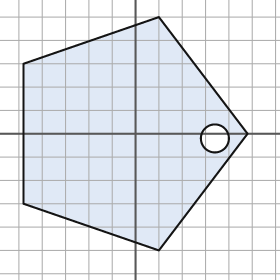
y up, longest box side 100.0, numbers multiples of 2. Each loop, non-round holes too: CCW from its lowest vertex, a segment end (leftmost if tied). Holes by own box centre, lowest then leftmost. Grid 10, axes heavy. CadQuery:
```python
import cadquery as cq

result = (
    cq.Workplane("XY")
    .moveTo(10.0, -50.0)
    .lineTo(48.0, 0.0)
    .lineTo(10.0, 50.0)
    .lineTo(-48.0, 30.0)
    .lineTo(-48.0, -30.0)
    .close()
    .moveTo(34.0, -2.0)
    .circle(6.0)
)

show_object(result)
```